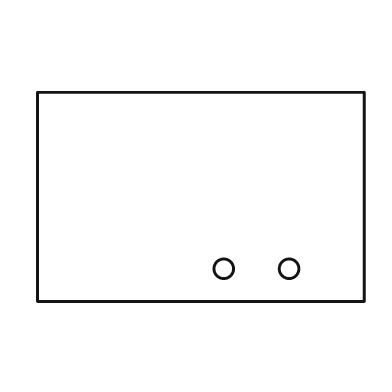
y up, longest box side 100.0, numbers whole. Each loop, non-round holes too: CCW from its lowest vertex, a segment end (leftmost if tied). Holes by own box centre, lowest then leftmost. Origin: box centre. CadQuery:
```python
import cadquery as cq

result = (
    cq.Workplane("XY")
    .moveTo(-50.0, -32.0)
    .lineTo(50.0, -32.0)
    .lineTo(50.0, 32.0)
    .lineTo(-50.0, 32.0)
    .close()
    .moveTo(7.0, -22.0)
    .circle(3.0)
    .moveTo(27.0, -22.0)
    .circle(3.0)
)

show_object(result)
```